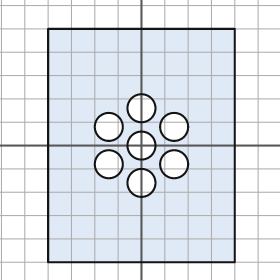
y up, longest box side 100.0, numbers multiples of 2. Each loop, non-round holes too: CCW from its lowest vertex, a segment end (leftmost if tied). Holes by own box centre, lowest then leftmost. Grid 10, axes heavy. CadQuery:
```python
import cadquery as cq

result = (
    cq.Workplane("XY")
    .moveTo(-40.0, -50.0)
    .lineTo(40.0, -50.0)
    .lineTo(40.0, 50.0)
    .lineTo(-40.0, 50.0)
    .close()
    .moveTo(0.0, -16.0)
    .circle(6.0)
    .moveTo(-14.0, -8.0)
    .circle(6.0)
    .moveTo(14.0, -8.0)
    .circle(6.0)
    .moveTo(0.0, 0.0)
    .circle(6.0)
    .moveTo(-14.0, 8.0)
    .circle(6.0)
    .moveTo(14.0, 8.0)
    .circle(6.0)
    .moveTo(0.0, 16.0)
    .circle(6.0)
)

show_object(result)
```